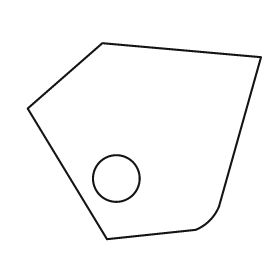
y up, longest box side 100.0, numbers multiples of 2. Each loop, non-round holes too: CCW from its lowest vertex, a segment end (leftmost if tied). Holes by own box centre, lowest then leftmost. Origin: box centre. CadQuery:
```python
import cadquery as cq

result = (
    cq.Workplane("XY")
    .moveTo(-16.0, -42.0)
    .lineTo(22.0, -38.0)
    .threePointArc((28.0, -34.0), (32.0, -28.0))
    .lineTo(50.0, 36.0)
    .lineTo(-18.0, 42.0)
    .lineTo(-50.0, 14.0)
    .close()
    .moveTo(-12.0, -16.0)
    .circle(10.0)
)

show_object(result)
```